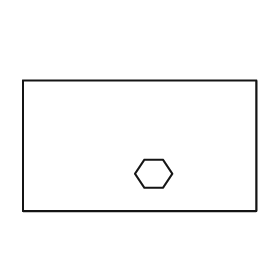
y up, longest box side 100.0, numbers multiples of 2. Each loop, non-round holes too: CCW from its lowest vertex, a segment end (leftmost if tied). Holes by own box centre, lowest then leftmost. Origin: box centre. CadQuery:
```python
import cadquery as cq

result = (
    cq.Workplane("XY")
    .moveTo(-50.0, -28.0)
    .lineTo(50.0, -28.0)
    .lineTo(50.0, 28.0)
    .lineTo(-50.0, 28.0)
    .close()
    .moveTo(2.0, -18.0)
    .lineTo(10.0, -18.0)
    .lineTo(14.0, -12.0)
    .lineTo(10.0, -6.0)
    .lineTo(2.0, -6.0)
    .lineTo(-2.0, -12.0)
    .close()
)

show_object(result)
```